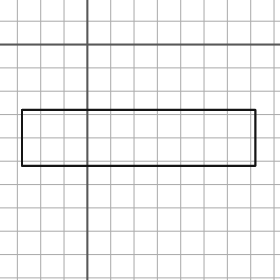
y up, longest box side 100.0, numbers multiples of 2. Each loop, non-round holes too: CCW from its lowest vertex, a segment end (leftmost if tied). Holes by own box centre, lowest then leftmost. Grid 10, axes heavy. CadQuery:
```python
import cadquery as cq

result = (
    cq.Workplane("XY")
    .moveTo(-28.0, -52.0)
    .lineTo(72.0, -52.0)
    .lineTo(72.0, -28.0)
    .lineTo(-28.0, -28.0)
    .close()
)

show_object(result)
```